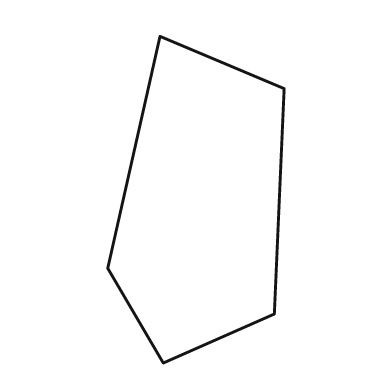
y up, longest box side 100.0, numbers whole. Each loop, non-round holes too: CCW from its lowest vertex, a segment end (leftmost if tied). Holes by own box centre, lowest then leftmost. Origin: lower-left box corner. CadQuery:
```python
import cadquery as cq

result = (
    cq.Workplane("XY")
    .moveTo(17.0, 0.0)
    .lineTo(51.0, 15.0)
    .lineTo(54.0, 84.0)
    .lineTo(16.0, 100.0)
    .lineTo(0.0, 29.0)
    .close()
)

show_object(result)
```